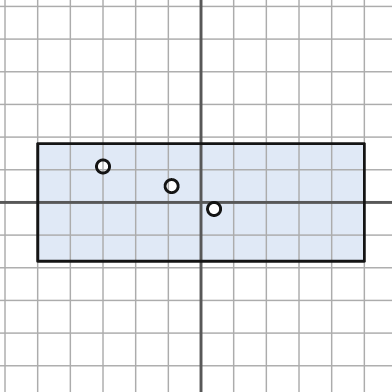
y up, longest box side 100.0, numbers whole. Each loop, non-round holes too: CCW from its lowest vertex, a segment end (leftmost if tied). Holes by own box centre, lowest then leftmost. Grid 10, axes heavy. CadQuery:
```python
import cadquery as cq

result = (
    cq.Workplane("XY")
    .moveTo(-50.0, -18.0)
    .lineTo(50.0, -18.0)
    .lineTo(50.0, 18.0)
    .lineTo(-50.0, 18.0)
    .close()
    .moveTo(4.0, -2.0)
    .circle(2.0)
    .moveTo(-9.0, 5.0)
    .circle(2.0)
    .moveTo(-30.0, 11.0)
    .circle(2.0)
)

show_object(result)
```